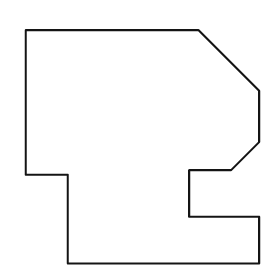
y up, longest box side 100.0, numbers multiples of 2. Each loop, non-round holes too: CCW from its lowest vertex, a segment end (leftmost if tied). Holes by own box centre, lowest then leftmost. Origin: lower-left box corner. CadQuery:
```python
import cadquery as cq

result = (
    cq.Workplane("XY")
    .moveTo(18.0, 0.0)
    .lineTo(100.0, 0.0)
    .lineTo(100.0, 20.0)
    .lineTo(70.0, 20.0)
    .lineTo(70.0, 40.0)
    .lineTo(88.0, 40.0)
    .lineTo(100.0, 52.0)
    .lineTo(100.0, 74.0)
    .lineTo(74.0, 100.0)
    .lineTo(0.0, 100.0)
    .lineTo(0.0, 38.0)
    .lineTo(18.0, 38.0)
    .close()
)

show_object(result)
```